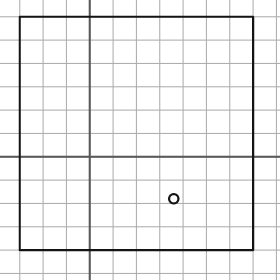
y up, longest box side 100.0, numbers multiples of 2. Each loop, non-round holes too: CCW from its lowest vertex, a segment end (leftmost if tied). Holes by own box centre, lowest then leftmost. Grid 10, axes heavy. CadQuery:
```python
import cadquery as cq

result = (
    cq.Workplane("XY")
    .moveTo(-30.0, -40.0)
    .lineTo(70.0, -40.0)
    .lineTo(70.0, 60.0)
    .lineTo(-30.0, 60.0)
    .close()
    .moveTo(36.0, -18.0)
    .circle(2.0)
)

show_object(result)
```